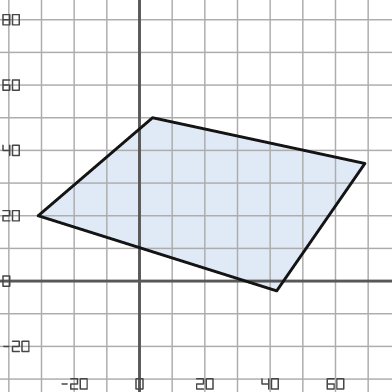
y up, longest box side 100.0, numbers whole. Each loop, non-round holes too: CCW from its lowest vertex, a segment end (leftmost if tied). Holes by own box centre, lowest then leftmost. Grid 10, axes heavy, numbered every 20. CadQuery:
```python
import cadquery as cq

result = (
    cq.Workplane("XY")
    .moveTo(42.0, -3.0)
    .lineTo(69.0, 36.0)
    .lineTo(4.0, 50.0)
    .lineTo(-31.0, 20.0)
    .close()
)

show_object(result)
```